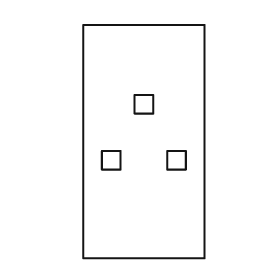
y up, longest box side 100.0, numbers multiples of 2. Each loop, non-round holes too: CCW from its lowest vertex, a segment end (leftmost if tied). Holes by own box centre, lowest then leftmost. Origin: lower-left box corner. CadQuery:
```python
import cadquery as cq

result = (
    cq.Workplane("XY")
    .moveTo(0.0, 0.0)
    .lineTo(52.0, 0.0)
    .lineTo(52.0, 100.0)
    .lineTo(0.0, 100.0)
    .close()
    .moveTo(8.0, 38.0)
    .lineTo(16.0, 38.0)
    .lineTo(16.0, 46.0)
    .lineTo(8.0, 46.0)
    .close()
    .moveTo(36.0, 38.0)
    .lineTo(44.0, 38.0)
    .lineTo(44.0, 46.0)
    .lineTo(36.0, 46.0)
    .close()
    .moveTo(22.0, 62.0)
    .lineTo(30.0, 62.0)
    .lineTo(30.0, 70.0)
    .lineTo(22.0, 70.0)
    .close()
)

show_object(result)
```